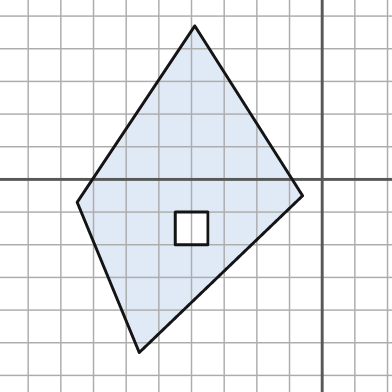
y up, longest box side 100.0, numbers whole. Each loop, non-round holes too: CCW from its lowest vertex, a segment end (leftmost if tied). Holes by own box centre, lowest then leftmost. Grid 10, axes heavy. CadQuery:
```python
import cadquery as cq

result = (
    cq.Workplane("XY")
    .moveTo(-56.0, -53.0)
    .lineTo(-6.0, -5.0)
    .lineTo(-39.0, 47.0)
    .lineTo(-75.0, -7.0)
    .close()
    .moveTo(-45.0, -20.0)
    .lineTo(-35.0, -20.0)
    .lineTo(-35.0, -10.0)
    .lineTo(-45.0, -10.0)
    .close()
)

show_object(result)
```